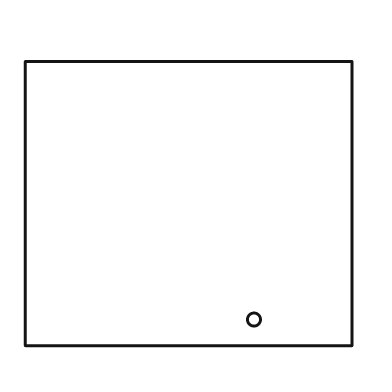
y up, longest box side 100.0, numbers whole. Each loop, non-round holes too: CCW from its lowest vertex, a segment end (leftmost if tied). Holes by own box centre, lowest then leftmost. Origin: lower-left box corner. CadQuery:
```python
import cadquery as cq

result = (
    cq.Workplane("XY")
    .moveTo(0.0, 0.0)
    .lineTo(100.0, 0.0)
    .lineTo(100.0, 87.0)
    .lineTo(0.0, 87.0)
    .close()
    .moveTo(70.0, 8.0)
    .circle(2.0)
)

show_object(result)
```